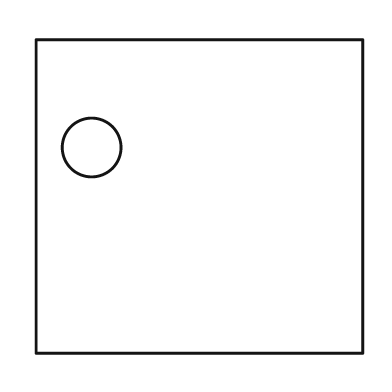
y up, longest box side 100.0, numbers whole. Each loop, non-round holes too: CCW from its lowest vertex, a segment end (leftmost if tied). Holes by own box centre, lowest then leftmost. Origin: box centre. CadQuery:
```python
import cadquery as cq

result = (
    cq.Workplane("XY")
    .moveTo(-50.0, -48.0)
    .lineTo(50.0, -48.0)
    .lineTo(50.0, 48.0)
    .lineTo(-50.0, 48.0)
    .close()
    .moveTo(-33.0, 15.0)
    .circle(9.0)
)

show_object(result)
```